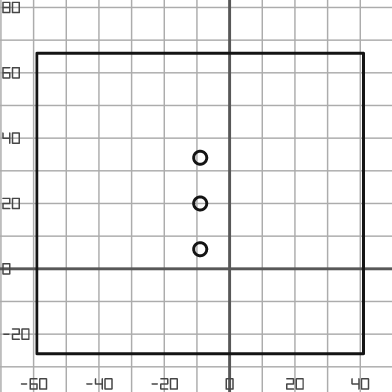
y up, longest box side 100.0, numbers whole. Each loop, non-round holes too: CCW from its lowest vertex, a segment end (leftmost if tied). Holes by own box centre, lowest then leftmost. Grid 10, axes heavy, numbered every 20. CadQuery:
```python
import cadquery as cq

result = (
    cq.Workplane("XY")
    .moveTo(-59.0, -26.0)
    .lineTo(41.0, -26.0)
    .lineTo(41.0, 66.0)
    .lineTo(-59.0, 66.0)
    .close()
    .moveTo(-9.0, 6.0)
    .circle(2.0)
    .moveTo(-9.0, 20.0)
    .circle(2.0)
    .moveTo(-9.0, 34.0)
    .circle(2.0)
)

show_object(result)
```